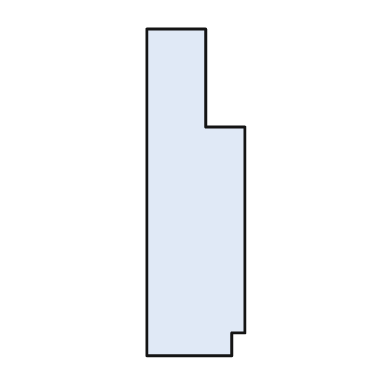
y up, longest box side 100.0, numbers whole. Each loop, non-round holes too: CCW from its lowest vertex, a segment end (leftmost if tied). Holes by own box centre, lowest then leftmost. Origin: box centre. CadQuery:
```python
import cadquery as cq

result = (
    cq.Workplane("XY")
    .moveTo(-15.0, -50.0)
    .lineTo(11.0, -50.0)
    .lineTo(11.0, -43.0)
    .lineTo(15.0, -43.0)
    .lineTo(15.0, 20.0)
    .lineTo(3.0, 20.0)
    .lineTo(3.0, 50.0)
    .lineTo(-15.0, 50.0)
    .close()
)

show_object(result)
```